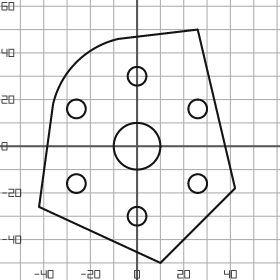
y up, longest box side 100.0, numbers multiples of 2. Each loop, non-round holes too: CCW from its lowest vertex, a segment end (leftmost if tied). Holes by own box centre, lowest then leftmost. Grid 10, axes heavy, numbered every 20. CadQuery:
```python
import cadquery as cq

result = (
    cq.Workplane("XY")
    .moveTo(10.0, -50.0)
    .lineTo(42.0, -18.0)
    .lineTo(26.0, 50.0)
    .lineTo(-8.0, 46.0)
    .threePointArc((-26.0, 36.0), (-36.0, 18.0))
    .lineTo(-42.0, -26.0)
    .close()
    .moveTo(0.0, -30.0)
    .circle(4.0)
    .moveTo(-26.0, -16.0)
    .circle(4.0)
    .moveTo(26.0, -16.0)
    .circle(4.0)
    .moveTo(0.0, 0.0)
    .circle(10.0)
    .moveTo(-26.0, 16.0)
    .circle(4.0)
    .moveTo(26.0, 16.0)
    .circle(4.0)
    .moveTo(0.0, 30.0)
    .circle(4.0)
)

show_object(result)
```